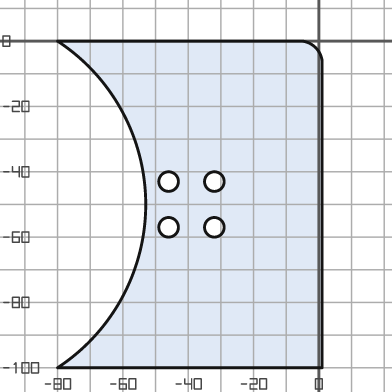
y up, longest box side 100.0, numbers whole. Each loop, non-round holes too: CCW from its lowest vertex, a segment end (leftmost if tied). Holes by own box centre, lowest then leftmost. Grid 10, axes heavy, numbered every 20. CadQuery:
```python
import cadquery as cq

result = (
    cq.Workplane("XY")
    .moveTo(-80.0, -100.0)
    .lineTo(1.0, -100.0)
    .lineTo(1.0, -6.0)
    .threePointArc((-1.0, -2.0), (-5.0, 0.0))
    .lineTo(-80.0, 0.0)
    .threePointArc((-53.0, -50.0), (-80.0, -100.0))
    .close()
    .moveTo(-46.0, -57.0)
    .circle(3.0)
    .moveTo(-32.0, -57.0)
    .circle(3.0)
    .moveTo(-46.0, -43.0)
    .circle(3.0)
    .moveTo(-32.0, -43.0)
    .circle(3.0)
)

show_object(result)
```